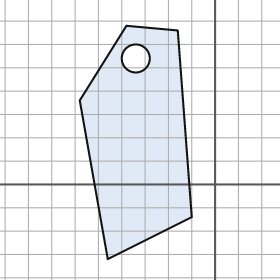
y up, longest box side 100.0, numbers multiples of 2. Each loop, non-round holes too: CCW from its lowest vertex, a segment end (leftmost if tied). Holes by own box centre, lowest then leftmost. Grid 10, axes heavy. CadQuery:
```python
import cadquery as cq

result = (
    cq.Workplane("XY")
    .moveTo(-46.0, -32.0)
    .lineTo(-10.0, -14.0)
    .lineTo(-16.0, 66.0)
    .lineTo(-38.0, 68.0)
    .lineTo(-58.0, 36.0)
    .close()
    .moveTo(-34.0, 54.0)
    .circle(6.0)
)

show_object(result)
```